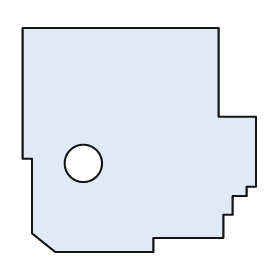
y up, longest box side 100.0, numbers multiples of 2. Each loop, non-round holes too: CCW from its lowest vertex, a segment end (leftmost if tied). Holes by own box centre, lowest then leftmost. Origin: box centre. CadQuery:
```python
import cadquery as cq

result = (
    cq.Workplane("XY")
    .moveTo(-36.0, -48.0)
    .lineTo(6.0, -48.0)
    .lineTo(6.0, -42.0)
    .lineTo(36.0, -42.0)
    .lineTo(36.0, -32.0)
    .lineTo(40.0, -32.0)
    .lineTo(40.0, -24.0)
    .lineTo(46.0, -24.0)
    .lineTo(46.0, -20.0)
    .lineTo(50.0, -20.0)
    .lineTo(50.0, 10.0)
    .lineTo(34.0, 10.0)
    .lineTo(34.0, 48.0)
    .lineTo(-50.0, 48.0)
    .lineTo(-50.0, -8.0)
    .lineTo(-46.0, -8.0)
    .lineTo(-46.0, -40.0)
    .close()
    .moveTo(-24.0, -10.0)
    .circle(8.0)
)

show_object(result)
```